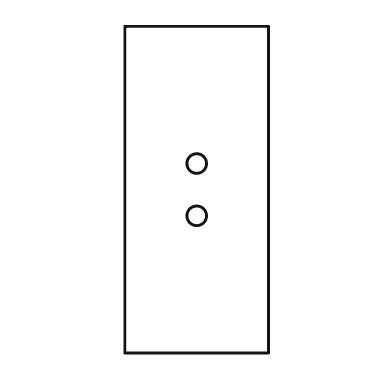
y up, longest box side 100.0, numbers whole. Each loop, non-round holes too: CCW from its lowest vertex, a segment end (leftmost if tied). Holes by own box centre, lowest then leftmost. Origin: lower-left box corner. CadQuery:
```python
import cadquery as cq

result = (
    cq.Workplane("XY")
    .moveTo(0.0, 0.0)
    .lineTo(44.0, 0.0)
    .lineTo(44.0, 100.0)
    .lineTo(0.0, 100.0)
    .close()
    .moveTo(22.0, 42.0)
    .circle(3.0)
    .moveTo(22.0, 58.0)
    .circle(3.0)
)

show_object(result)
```